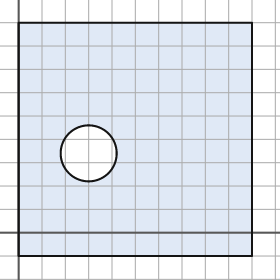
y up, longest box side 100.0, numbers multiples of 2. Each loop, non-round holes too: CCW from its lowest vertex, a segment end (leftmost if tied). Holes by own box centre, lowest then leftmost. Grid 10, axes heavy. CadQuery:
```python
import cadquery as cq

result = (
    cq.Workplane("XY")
    .moveTo(0.0, -10.0)
    .lineTo(100.0, -10.0)
    .lineTo(100.0, 90.0)
    .lineTo(0.0, 90.0)
    .close()
    .moveTo(30.0, 34.0)
    .circle(12.0)
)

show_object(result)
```